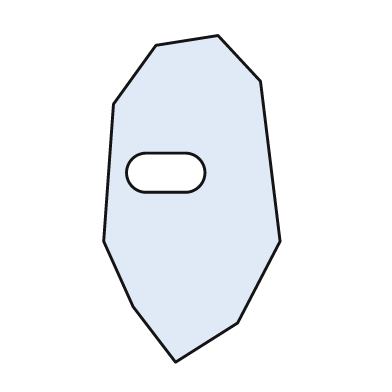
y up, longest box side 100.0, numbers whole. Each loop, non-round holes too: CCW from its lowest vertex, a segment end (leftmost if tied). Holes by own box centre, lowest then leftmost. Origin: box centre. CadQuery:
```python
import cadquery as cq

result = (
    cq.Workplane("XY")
    .moveTo(-5.0, -50.0)
    .lineTo(14.0, -38.0)
    .lineTo(27.0, -13.0)
    .lineTo(21.0, 36.0)
    .lineTo(8.0, 50.0)
    .lineTo(-11.0, 47.0)
    .lineTo(-24.0, 29.0)
    .lineTo(-27.0, -13.0)
    .lineTo(-18.0, -33.0)
    .close()
    .moveTo(-14.0, 2.0)
    .lineTo(-2.0, 2.0)
    .threePointArc((4.0, 8.0), (-2.0, 14.0))
    .lineTo(-14.0, 14.0)
    .threePointArc((-20.0, 8.0), (-14.0, 2.0))
    .close()
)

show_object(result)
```